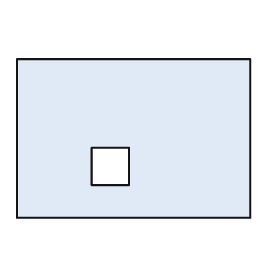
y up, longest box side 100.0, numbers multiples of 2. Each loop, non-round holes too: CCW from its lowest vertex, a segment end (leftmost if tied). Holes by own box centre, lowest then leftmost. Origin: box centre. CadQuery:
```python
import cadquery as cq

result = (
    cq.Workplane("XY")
    .moveTo(-50.0, -34.0)
    .lineTo(50.0, -34.0)
    .lineTo(50.0, 34.0)
    .lineTo(-50.0, 34.0)
    .close()
    .moveTo(-18.0, -20.0)
    .lineTo(-2.0, -20.0)
    .lineTo(-2.0, -4.0)
    .lineTo(-18.0, -4.0)
    .close()
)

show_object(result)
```